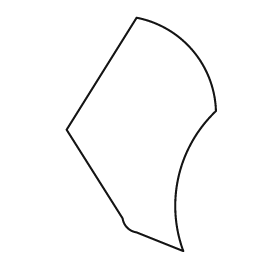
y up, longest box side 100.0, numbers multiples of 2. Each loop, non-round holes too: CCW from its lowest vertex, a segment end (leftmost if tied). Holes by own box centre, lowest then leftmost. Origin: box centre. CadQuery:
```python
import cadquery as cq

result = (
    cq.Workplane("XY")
    .moveTo(18.0, -50.0)
    .threePointArc((16.0, -18.0), (32.0, 10.0))
    .threePointArc((22.0, 36.0), (-2.0, 50.0))
    .lineTo(-32.0, 2.0)
    .lineTo(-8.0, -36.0)
    .threePointArc((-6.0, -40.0), (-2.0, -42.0))
    .close()
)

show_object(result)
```